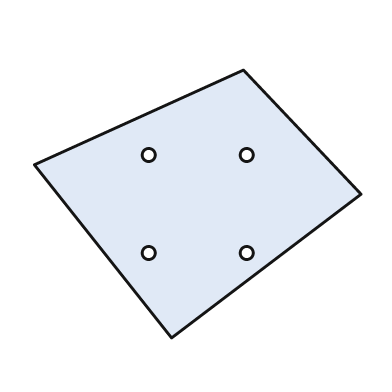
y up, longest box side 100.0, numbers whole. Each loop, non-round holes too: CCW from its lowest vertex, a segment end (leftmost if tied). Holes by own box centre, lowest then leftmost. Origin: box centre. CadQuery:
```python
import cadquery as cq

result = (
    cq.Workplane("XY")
    .moveTo(-8.0, -41.0)
    .lineTo(50.0, 3.0)
    .lineTo(14.0, 41.0)
    .lineTo(-50.0, 12.0)
    .close()
    .moveTo(-15.0, -15.0)
    .circle(2.0)
    .moveTo(15.0, -15.0)
    .circle(2.0)
    .moveTo(-15.0, 15.0)
    .circle(2.0)
    .moveTo(15.0, 15.0)
    .circle(2.0)
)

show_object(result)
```